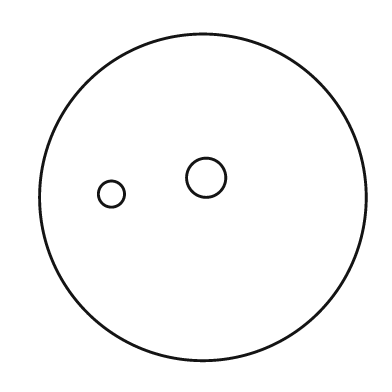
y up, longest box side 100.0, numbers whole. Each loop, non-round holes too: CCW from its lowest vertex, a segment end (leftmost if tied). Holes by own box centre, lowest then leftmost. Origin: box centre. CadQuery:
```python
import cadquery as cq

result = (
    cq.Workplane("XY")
    .moveTo(0.0, 0.0)
    .circle(50.0)
    .moveTo(-28.0, 1.0)
    .circle(4.0)
    .moveTo(1.0, 6.0)
    .circle(6.0)
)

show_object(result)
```